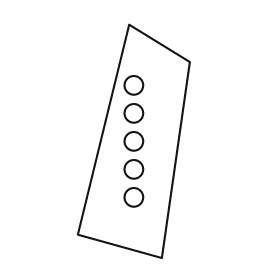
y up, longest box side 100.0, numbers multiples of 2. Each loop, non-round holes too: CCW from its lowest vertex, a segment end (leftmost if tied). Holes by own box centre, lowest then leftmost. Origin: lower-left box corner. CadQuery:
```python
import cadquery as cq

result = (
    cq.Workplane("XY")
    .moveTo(36.0, 0.0)
    .lineTo(48.0, 84.0)
    .lineTo(22.0, 100.0)
    .lineTo(0.0, 10.0)
    .close()
    .moveTo(24.0, 26.0)
    .circle(4.0)
    .moveTo(24.0, 38.0)
    .circle(4.0)
    .moveTo(24.0, 50.0)
    .circle(4.0)
    .moveTo(24.0, 62.0)
    .circle(4.0)
    .moveTo(24.0, 74.0)
    .circle(4.0)
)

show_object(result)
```